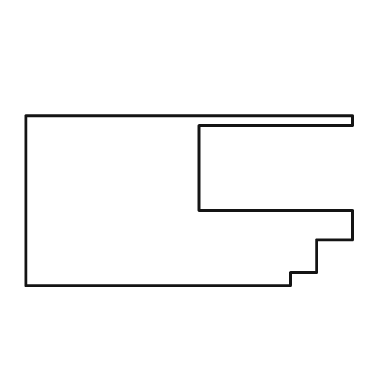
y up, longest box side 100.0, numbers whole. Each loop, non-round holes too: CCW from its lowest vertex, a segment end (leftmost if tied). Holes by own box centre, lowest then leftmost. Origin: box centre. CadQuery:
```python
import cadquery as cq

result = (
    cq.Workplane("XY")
    .moveTo(-50.0, -26.0)
    .lineTo(31.0, -26.0)
    .lineTo(31.0, -22.0)
    .lineTo(39.0, -22.0)
    .lineTo(39.0, -12.0)
    .lineTo(50.0, -12.0)
    .lineTo(50.0, -3.0)
    .lineTo(3.0, -3.0)
    .lineTo(3.0, 23.0)
    .lineTo(50.0, 23.0)
    .lineTo(50.0, 26.0)
    .lineTo(-50.0, 26.0)
    .close()
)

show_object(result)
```